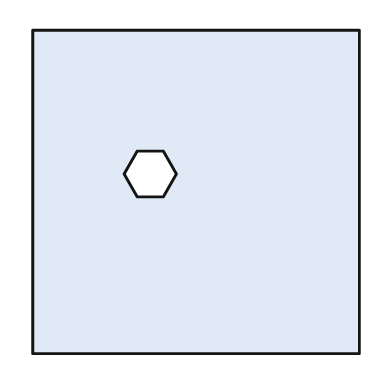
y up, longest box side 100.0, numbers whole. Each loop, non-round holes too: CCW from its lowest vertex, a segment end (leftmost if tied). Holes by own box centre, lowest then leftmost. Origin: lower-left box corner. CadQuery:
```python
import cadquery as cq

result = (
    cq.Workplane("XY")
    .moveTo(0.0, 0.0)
    .lineTo(100.0, 0.0)
    .lineTo(100.0, 99.0)
    .lineTo(0.0, 99.0)
    .close()
    .moveTo(32.0, 48.0)
    .lineTo(40.0, 48.0)
    .lineTo(44.0, 55.0)
    .lineTo(40.0, 62.0)
    .lineTo(32.0, 62.0)
    .lineTo(28.0, 55.0)
    .close()
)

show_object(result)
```